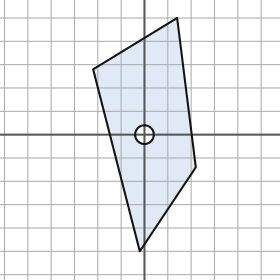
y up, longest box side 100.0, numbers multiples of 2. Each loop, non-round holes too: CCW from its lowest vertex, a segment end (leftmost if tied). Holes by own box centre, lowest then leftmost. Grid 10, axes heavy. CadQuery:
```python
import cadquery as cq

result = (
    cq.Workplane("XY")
    .moveTo(-2.0, -50.0)
    .lineTo(22.0, -14.0)
    .lineTo(14.0, 50.0)
    .lineTo(-22.0, 28.0)
    .close()
    .moveTo(0.0, 0.0)
    .circle(4.0)
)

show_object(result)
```